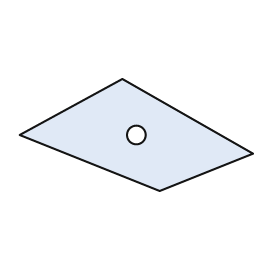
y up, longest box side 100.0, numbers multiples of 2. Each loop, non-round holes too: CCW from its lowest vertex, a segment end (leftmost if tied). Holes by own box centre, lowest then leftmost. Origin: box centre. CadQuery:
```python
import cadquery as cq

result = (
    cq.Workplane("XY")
    .moveTo(10.0, -24.0)
    .lineTo(50.0, -8.0)
    .lineTo(-6.0, 24.0)
    .lineTo(-50.0, 0.0)
    .close()
    .moveTo(0.0, 0.0)
    .circle(4.0)
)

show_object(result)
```